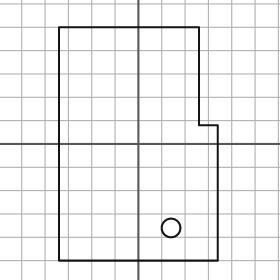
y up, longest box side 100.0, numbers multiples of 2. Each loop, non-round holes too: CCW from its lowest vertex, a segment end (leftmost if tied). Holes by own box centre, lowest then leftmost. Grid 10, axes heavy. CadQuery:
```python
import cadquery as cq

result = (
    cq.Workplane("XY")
    .moveTo(-34.0, -50.0)
    .lineTo(34.0, -50.0)
    .lineTo(34.0, 8.0)
    .lineTo(26.0, 8.0)
    .lineTo(26.0, 50.0)
    .lineTo(-34.0, 50.0)
    .close()
    .moveTo(14.0, -36.0)
    .circle(4.0)
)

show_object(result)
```